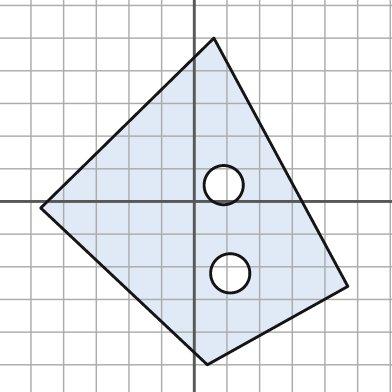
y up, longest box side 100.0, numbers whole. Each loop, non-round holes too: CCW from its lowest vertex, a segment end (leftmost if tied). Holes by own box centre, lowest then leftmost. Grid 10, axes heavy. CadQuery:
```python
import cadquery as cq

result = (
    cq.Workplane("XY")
    .moveTo(4.0, -50.0)
    .lineTo(47.0, -26.0)
    .lineTo(6.0, 50.0)
    .lineTo(-47.0, -2.0)
    .close()
    .moveTo(11.0, -22.0)
    .circle(6.0)
    .moveTo(9.0, 5.0)
    .circle(6.0)
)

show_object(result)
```